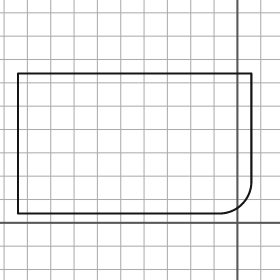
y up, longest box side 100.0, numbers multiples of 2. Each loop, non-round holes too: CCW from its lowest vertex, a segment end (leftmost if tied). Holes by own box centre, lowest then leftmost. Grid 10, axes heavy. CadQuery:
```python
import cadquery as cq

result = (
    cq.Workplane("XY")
    .moveTo(-94.0, 4.0)
    .lineTo(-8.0, 4.0)
    .threePointArc((2.0, 8.0), (6.0, 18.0))
    .lineTo(6.0, 64.0)
    .lineTo(-94.0, 64.0)
    .close()
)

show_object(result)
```